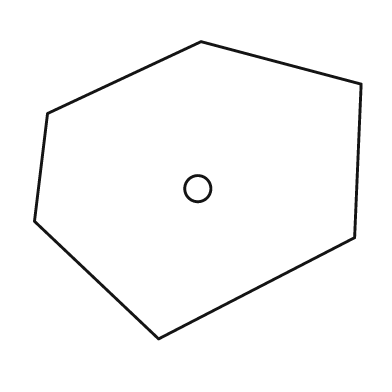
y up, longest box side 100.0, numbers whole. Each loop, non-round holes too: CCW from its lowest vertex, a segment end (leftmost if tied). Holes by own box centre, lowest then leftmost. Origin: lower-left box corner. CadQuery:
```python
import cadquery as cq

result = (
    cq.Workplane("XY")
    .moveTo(38.0, 0.0)
    .lineTo(98.0, 31.0)
    .lineTo(100.0, 78.0)
    .lineTo(51.0, 91.0)
    .lineTo(4.0, 69.0)
    .lineTo(0.0, 36.0)
    .close()
    .moveTo(50.0, 46.0)
    .circle(4.0)
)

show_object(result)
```